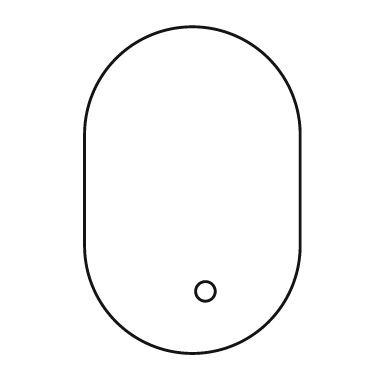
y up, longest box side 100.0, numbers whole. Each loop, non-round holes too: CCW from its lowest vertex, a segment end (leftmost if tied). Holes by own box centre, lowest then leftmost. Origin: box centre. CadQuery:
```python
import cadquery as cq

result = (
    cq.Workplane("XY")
    .moveTo(-33.0, -17.0)
    .threePointArc((0.0, -50.0), (33.0, -17.0))
    .lineTo(33.0, 17.0)
    .threePointArc((0.0, 50.0), (-33.0, 17.0))
    .close()
    .moveTo(4.0, -31.0)
    .circle(3.0)
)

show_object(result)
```